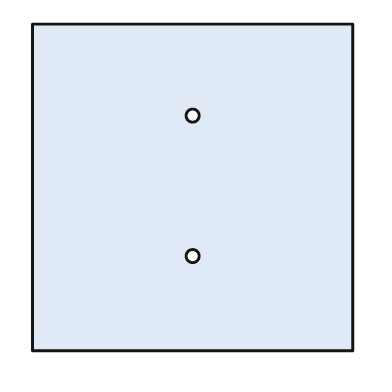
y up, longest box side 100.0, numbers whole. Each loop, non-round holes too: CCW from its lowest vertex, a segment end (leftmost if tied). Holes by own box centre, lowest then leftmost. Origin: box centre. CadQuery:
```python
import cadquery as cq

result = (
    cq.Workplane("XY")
    .moveTo(-49.0, -50.0)
    .lineTo(49.0, -50.0)
    .lineTo(49.0, 50.0)
    .lineTo(-49.0, 50.0)
    .close()
    .moveTo(0.0, -21.0)
    .circle(2.0)
    .moveTo(0.0, 22.0)
    .circle(2.0)
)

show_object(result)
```